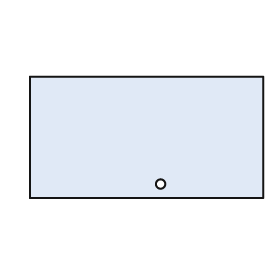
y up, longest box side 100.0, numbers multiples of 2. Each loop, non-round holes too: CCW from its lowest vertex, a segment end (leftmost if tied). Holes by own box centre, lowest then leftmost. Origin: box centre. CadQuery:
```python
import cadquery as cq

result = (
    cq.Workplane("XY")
    .moveTo(-50.0, -26.0)
    .lineTo(50.0, -26.0)
    .lineTo(50.0, 26.0)
    .lineTo(-50.0, 26.0)
    .close()
    .moveTo(6.0, -20.0)
    .circle(2.0)
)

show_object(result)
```